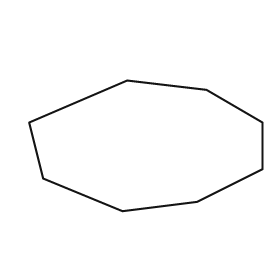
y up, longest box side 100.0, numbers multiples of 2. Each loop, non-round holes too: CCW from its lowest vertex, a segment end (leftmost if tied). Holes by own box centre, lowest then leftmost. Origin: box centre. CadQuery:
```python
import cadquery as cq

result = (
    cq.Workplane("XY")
    .moveTo(-10.0, -28.0)
    .lineTo(22.0, -24.0)
    .lineTo(50.0, -10.0)
    .lineTo(50.0, 10.0)
    .lineTo(26.0, 24.0)
    .lineTo(-8.0, 28.0)
    .lineTo(-50.0, 10.0)
    .lineTo(-44.0, -14.0)
    .close()
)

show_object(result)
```